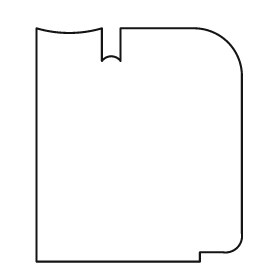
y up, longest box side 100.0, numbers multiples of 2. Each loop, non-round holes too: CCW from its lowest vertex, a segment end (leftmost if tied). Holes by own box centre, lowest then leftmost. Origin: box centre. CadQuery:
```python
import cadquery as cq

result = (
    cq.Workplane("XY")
    .moveTo(-44.0, -50.0)
    .lineTo(26.0, -50.0)
    .lineTo(26.0, -46.0)
    .lineTo(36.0, -46.0)
    .threePointArc((42.0, -44.0), (44.0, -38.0))
    .lineTo(44.0, 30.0)
    .threePointArc((38.0, 44.0), (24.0, 50.0))
    .lineTo(-8.0, 50.0)
    .lineTo(-8.0, 36.0)
    .threePointArc((-12.0, 38.0), (-16.0, 36.0))
    .lineTo(-16.0, 50.0)
    .threePointArc((-30.0, 48.0), (-44.0, 50.0))
    .close()
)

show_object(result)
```